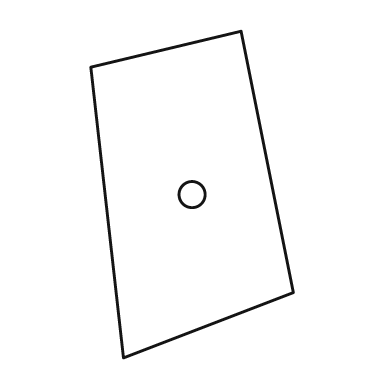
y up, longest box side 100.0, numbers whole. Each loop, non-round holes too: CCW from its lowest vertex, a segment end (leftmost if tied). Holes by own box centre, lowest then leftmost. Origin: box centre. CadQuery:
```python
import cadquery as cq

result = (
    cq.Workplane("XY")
    .moveTo(-21.0, -50.0)
    .lineTo(31.0, -30.0)
    .lineTo(15.0, 50.0)
    .lineTo(-31.0, 39.0)
    .close()
    .moveTo(0.0, 0.0)
    .circle(4.0)
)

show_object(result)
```